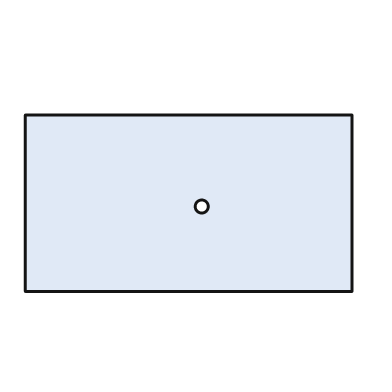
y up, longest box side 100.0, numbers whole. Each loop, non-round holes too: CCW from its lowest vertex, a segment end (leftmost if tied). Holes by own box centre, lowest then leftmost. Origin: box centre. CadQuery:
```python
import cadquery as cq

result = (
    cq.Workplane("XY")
    .moveTo(-50.0, -27.0)
    .lineTo(50.0, -27.0)
    .lineTo(50.0, 27.0)
    .lineTo(-50.0, 27.0)
    .close()
    .moveTo(4.0, -1.0)
    .circle(2.0)
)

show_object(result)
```